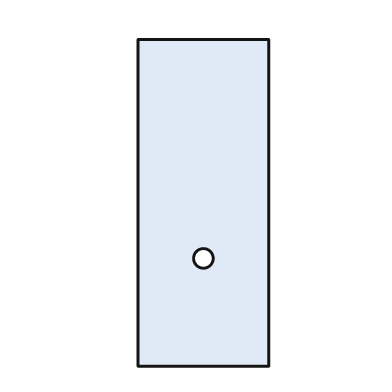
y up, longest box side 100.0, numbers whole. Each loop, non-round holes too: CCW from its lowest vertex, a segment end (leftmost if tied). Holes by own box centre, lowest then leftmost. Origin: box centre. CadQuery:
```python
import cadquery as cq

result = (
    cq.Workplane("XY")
    .moveTo(-20.0, -50.0)
    .lineTo(20.0, -50.0)
    .lineTo(20.0, 50.0)
    .lineTo(-20.0, 50.0)
    .close()
    .moveTo(0.0, -17.0)
    .circle(3.0)
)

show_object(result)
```